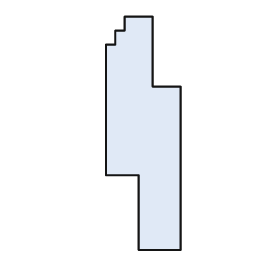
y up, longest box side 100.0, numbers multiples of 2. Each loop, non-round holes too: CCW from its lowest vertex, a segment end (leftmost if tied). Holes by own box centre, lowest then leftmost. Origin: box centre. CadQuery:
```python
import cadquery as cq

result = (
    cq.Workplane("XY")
    .moveTo(-2.0, -50.0)
    .lineTo(16.0, -50.0)
    .lineTo(16.0, 20.0)
    .lineTo(4.0, 20.0)
    .lineTo(4.0, 50.0)
    .lineTo(-8.0, 50.0)
    .lineTo(-8.0, 44.0)
    .lineTo(-12.0, 44.0)
    .lineTo(-12.0, 38.0)
    .lineTo(-16.0, 38.0)
    .lineTo(-16.0, -18.0)
    .lineTo(-2.0, -18.0)
    .close()
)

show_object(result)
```